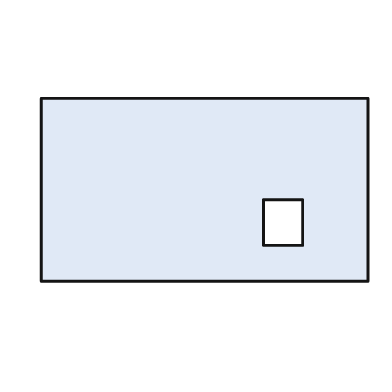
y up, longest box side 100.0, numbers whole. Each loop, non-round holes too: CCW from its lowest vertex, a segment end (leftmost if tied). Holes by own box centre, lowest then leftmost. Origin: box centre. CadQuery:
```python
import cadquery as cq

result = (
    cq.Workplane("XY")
    .moveTo(-50.0, -28.0)
    .lineTo(50.0, -28.0)
    .lineTo(50.0, 28.0)
    .lineTo(-50.0, 28.0)
    .close()
    .moveTo(18.0, -17.0)
    .lineTo(30.0, -17.0)
    .lineTo(30.0, -3.0)
    .lineTo(18.0, -3.0)
    .close()
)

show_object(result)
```